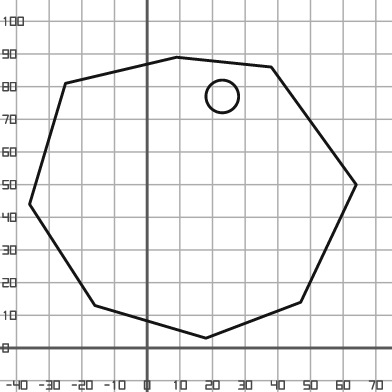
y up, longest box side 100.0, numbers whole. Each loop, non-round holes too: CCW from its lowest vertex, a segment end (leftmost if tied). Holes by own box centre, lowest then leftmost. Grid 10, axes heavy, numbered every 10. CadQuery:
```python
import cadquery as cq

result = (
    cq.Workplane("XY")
    .moveTo(18.0, 3.0)
    .lineTo(47.0, 14.0)
    .lineTo(64.0, 50.0)
    .lineTo(38.0, 86.0)
    .lineTo(9.0, 89.0)
    .lineTo(-25.0, 81.0)
    .lineTo(-36.0, 44.0)
    .lineTo(-16.0, 13.0)
    .close()
    .moveTo(23.0, 77.0)
    .circle(5.0)
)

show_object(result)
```